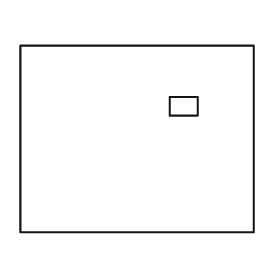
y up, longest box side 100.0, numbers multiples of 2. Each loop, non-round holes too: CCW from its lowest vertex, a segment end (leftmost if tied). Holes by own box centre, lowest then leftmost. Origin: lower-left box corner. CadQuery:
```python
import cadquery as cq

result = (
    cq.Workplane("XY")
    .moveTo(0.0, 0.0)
    .lineTo(100.0, 0.0)
    .lineTo(100.0, 80.0)
    .lineTo(0.0, 80.0)
    .close()
    .moveTo(64.0, 50.0)
    .lineTo(76.0, 50.0)
    .lineTo(76.0, 58.0)
    .lineTo(64.0, 58.0)
    .close()
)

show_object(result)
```